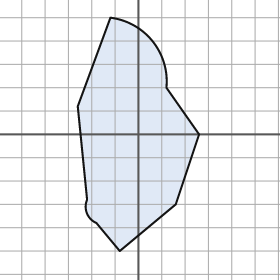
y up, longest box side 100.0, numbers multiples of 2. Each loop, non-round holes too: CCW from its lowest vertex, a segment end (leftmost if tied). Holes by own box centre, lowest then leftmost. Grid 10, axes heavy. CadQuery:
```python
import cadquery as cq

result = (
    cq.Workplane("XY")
    .moveTo(-8.0, -50.0)
    .lineTo(16.0, -30.0)
    .lineTo(26.0, 0.0)
    .lineTo(12.0, 20.0)
    .threePointArc((6.0, 40.0), (-12.0, 50.0))
    .lineTo(-26.0, 12.0)
    .lineTo(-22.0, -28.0)
    .threePointArc((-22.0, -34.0), (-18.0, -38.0))
    .close()
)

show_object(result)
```